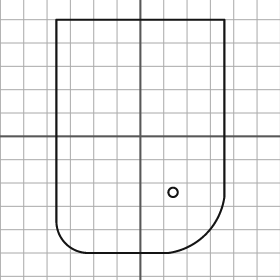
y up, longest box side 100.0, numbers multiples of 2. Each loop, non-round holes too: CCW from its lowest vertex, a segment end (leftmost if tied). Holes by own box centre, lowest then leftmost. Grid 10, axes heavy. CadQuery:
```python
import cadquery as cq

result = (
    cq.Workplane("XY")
    .moveTo(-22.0, -50.0)
    .lineTo(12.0, -50.0)
    .threePointArc((28.0, -42.0), (36.0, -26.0))
    .lineTo(36.0, 50.0)
    .lineTo(-36.0, 50.0)
    .lineTo(-36.0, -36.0)
    .threePointArc((-32.0, -46.0), (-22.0, -50.0))
    .close()
    .moveTo(14.0, -24.0)
    .circle(2.0)
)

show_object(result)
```